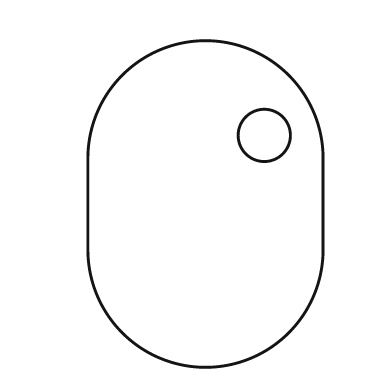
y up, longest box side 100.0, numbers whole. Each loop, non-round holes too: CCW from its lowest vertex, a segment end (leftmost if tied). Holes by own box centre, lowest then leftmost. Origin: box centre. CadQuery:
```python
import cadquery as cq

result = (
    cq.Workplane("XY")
    .moveTo(-36.0, -14.0)
    .threePointArc((0.0, -50.0), (36.0, -14.0))
    .lineTo(36.0, 14.0)
    .threePointArc((0.0, 50.0), (-36.0, 14.0))
    .close()
    .moveTo(18.0, 21.0)
    .circle(8.0)
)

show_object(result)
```